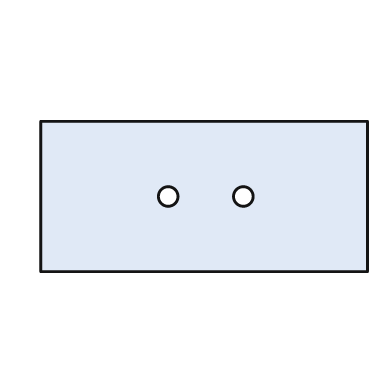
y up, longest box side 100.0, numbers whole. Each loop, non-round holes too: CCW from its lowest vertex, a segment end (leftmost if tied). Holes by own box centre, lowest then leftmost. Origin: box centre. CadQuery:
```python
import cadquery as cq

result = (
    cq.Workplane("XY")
    .moveTo(-50.0, -23.0)
    .lineTo(50.0, -23.0)
    .lineTo(50.0, 23.0)
    .lineTo(-50.0, 23.0)
    .close()
    .moveTo(-11.0, 0.0)
    .circle(3.0)
    .moveTo(12.0, 0.0)
    .circle(3.0)
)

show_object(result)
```